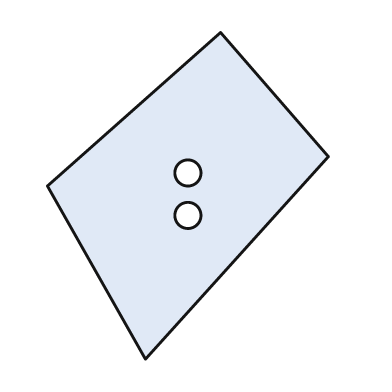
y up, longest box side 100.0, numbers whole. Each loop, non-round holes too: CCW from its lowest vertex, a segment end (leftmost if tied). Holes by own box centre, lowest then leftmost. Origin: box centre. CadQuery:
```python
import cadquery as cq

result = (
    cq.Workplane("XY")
    .moveTo(-13.0, -50.0)
    .lineTo(43.0, 12.0)
    .lineTo(10.0, 50.0)
    .lineTo(-43.0, 3.0)
    .close()
    .moveTo(0.0, -6.0)
    .circle(4.0)
    .moveTo(0.0, 7.0)
    .circle(4.0)
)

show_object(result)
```